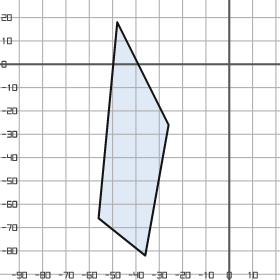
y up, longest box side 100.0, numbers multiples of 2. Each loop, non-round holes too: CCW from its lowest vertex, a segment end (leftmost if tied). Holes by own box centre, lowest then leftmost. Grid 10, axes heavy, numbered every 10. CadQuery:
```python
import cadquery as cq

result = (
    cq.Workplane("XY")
    .moveTo(-36.0, -82.0)
    .lineTo(-26.0, -26.0)
    .lineTo(-48.0, 18.0)
    .lineTo(-56.0, -66.0)
    .close()
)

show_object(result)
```